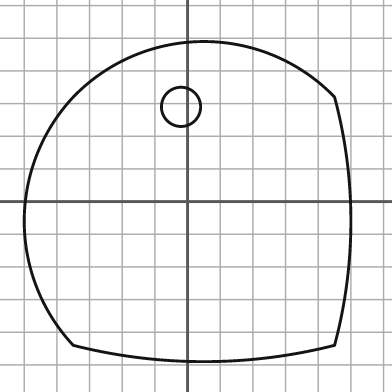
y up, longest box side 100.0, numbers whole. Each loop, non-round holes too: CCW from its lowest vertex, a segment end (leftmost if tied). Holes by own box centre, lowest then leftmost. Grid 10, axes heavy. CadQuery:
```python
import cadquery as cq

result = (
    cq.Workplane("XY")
    .moveTo(-35.0, -44.0)
    .threePointArc((5.0, -49.0), (45.0, -44.0))
    .threePointArc((50.0, -6.0), (45.0, 32.0))
    .threePointArc((5.0, 49.0), (-35.0, 32.0))
    .threePointArc((-50.0, -6.0), (-35.0, -44.0))
    .close()
    .moveTo(-2.0, 29.0)
    .circle(6.0)
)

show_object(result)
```